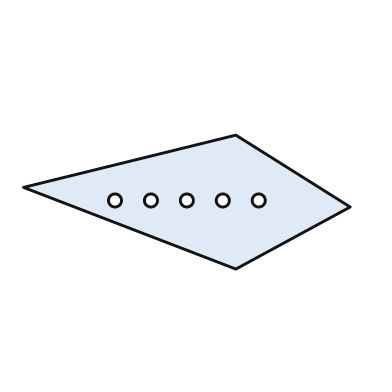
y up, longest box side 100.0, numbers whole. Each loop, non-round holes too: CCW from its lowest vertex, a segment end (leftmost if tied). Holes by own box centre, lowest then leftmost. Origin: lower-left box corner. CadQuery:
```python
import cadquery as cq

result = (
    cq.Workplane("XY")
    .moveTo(65.0, 0.0)
    .lineTo(100.0, 19.0)
    .lineTo(65.0, 41.0)
    .lineTo(0.0, 25.0)
    .close()
    .moveTo(28.0, 21.0)
    .circle(2.0)
    .moveTo(39.0, 21.0)
    .circle(2.0)
    .moveTo(50.0, 21.0)
    .circle(2.0)
    .moveTo(61.0, 21.0)
    .circle(2.0)
    .moveTo(72.0, 21.0)
    .circle(2.0)
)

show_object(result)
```